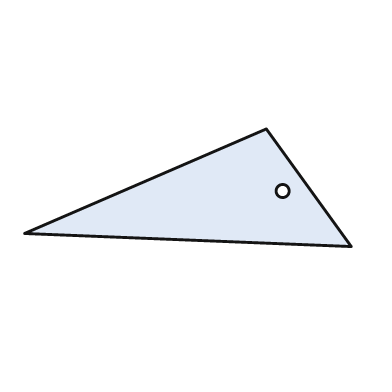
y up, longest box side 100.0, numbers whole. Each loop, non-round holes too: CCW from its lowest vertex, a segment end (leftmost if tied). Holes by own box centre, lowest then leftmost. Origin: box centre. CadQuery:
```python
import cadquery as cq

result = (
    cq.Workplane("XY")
    .moveTo(50.0, -18.0)
    .lineTo(24.0, 18.0)
    .lineTo(-50.0, -14.0)
    .close()
    .moveTo(29.0, -1.0)
    .circle(2.0)
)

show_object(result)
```